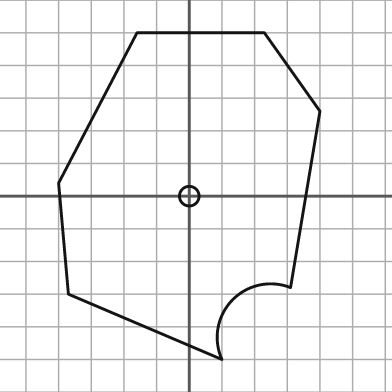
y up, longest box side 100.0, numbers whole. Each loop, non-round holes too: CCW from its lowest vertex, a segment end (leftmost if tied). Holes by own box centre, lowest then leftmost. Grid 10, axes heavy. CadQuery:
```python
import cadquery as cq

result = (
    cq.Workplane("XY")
    .moveTo(10.0, -50.0)
    .threePointArc((13.0, -32.0), (31.0, -28.0))
    .lineTo(40.0, 26.0)
    .lineTo(23.0, 50.0)
    .lineTo(-16.0, 50.0)
    .lineTo(-40.0, 4.0)
    .lineTo(-37.0, -30.0)
    .close()
    .moveTo(0.0, 0.0)
    .circle(3.0)
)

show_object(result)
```